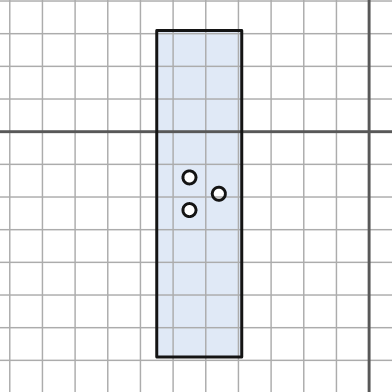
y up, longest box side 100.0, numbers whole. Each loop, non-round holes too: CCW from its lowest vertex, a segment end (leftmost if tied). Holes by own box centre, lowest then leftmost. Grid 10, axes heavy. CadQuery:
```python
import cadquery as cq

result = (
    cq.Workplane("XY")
    .moveTo(-65.0, -69.0)
    .lineTo(-39.0, -69.0)
    .lineTo(-39.0, 31.0)
    .lineTo(-65.0, 31.0)
    .close()
    .moveTo(-55.0, -24.0)
    .circle(2.0)
    .moveTo(-46.0, -19.0)
    .circle(2.0)
    .moveTo(-55.0, -14.0)
    .circle(2.0)
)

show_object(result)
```